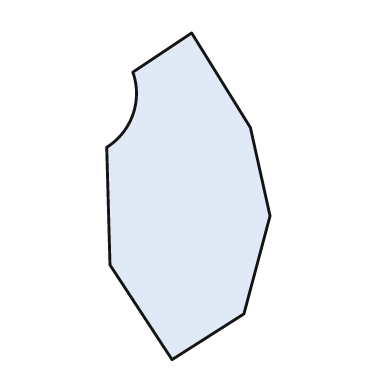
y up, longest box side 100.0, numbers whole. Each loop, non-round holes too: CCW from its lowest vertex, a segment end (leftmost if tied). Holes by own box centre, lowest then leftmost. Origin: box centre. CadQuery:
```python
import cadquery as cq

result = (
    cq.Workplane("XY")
    .moveTo(-5.0, -50.0)
    .lineTo(17.0, -36.0)
    .lineTo(25.0, -6.0)
    .lineTo(19.0, 21.0)
    .lineTo(1.0, 50.0)
    .lineTo(-17.0, 38.0)
    .threePointArc((-17.0, 25.0), (-25.0, 15.0))
    .lineTo(-24.0, -21.0)
    .close()
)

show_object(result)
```